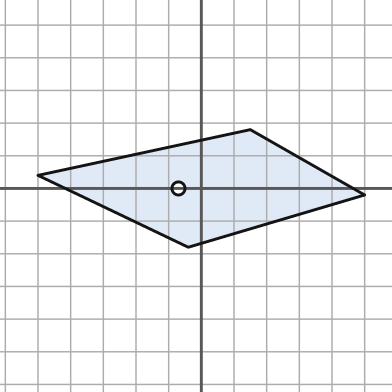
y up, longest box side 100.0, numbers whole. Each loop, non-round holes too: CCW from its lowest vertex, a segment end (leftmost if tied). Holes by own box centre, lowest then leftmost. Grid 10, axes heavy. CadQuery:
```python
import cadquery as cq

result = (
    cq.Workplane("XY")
    .moveTo(-4.0, -18.0)
    .lineTo(50.0, -2.0)
    .lineTo(15.0, 18.0)
    .lineTo(-50.0, 4.0)
    .close()
    .moveTo(-7.0, 0.0)
    .circle(2.0)
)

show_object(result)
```